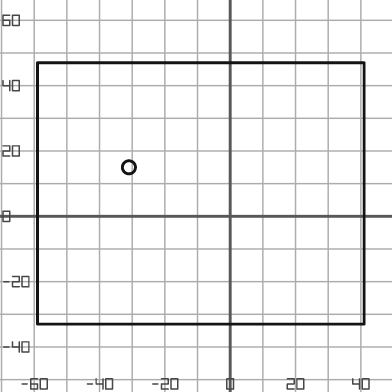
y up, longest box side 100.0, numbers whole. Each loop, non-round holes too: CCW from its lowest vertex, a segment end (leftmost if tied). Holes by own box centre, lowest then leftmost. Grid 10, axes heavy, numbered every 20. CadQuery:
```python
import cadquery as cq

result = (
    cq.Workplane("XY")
    .moveTo(-59.0, -33.0)
    .lineTo(41.0, -33.0)
    .lineTo(41.0, 47.0)
    .lineTo(-59.0, 47.0)
    .close()
    .moveTo(-31.0, 15.0)
    .circle(2.0)
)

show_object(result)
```